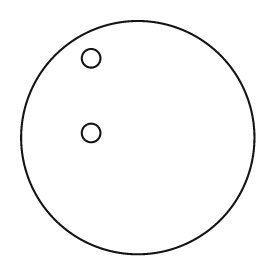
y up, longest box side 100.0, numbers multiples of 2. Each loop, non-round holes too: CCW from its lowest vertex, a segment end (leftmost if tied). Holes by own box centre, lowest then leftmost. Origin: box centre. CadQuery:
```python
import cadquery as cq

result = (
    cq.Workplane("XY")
    .moveTo(0.0, 0.0)
    .circle(50.0)
    .moveTo(-20.0, 2.0)
    .circle(4.0)
    .moveTo(-20.0, 34.0)
    .circle(4.0)
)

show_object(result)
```